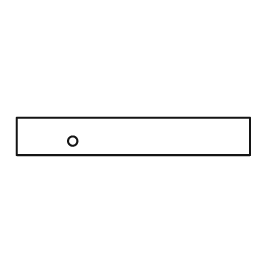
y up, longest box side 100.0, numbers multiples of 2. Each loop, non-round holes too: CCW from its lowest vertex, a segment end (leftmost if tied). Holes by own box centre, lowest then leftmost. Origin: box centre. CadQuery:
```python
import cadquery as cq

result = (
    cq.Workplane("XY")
    .moveTo(-50.0, -8.0)
    .lineTo(50.0, -8.0)
    .lineTo(50.0, 8.0)
    .lineTo(-50.0, 8.0)
    .close()
    .moveTo(-26.0, -2.0)
    .circle(2.0)
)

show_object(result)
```